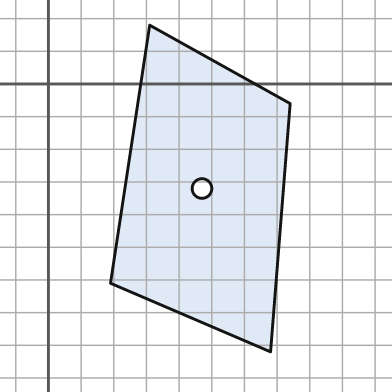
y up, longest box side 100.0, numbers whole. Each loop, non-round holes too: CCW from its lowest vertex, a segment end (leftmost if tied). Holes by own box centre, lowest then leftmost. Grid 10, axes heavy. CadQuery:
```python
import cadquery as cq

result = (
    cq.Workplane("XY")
    .moveTo(68.0, -82.0)
    .lineTo(74.0, -6.0)
    .lineTo(31.0, 18.0)
    .lineTo(19.0, -61.0)
    .close()
    .moveTo(47.0, -32.0)
    .circle(3.0)
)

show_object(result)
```